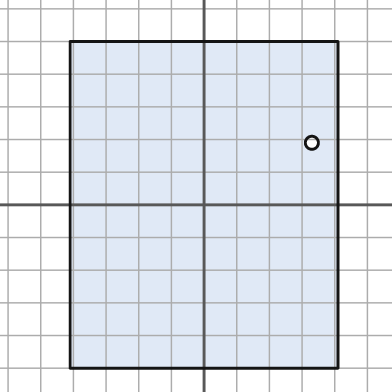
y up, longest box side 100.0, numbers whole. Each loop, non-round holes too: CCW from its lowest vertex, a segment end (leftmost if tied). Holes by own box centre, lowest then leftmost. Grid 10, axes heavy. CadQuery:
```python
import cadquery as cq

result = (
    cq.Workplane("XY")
    .moveTo(-41.0, -50.0)
    .lineTo(41.0, -50.0)
    .lineTo(41.0, 50.0)
    .lineTo(-41.0, 50.0)
    .close()
    .moveTo(33.0, 19.0)
    .circle(2.0)
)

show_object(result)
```